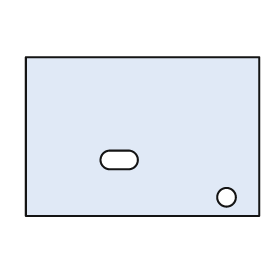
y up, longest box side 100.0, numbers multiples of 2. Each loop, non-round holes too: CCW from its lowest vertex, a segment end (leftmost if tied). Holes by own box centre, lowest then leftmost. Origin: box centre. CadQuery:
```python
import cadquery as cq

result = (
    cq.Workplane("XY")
    .moveTo(-50.0, -34.0)
    .lineTo(50.0, -34.0)
    .lineTo(50.0, 34.0)
    .lineTo(-50.0, 34.0)
    .close()
    .moveTo(36.0, -26.0)
    .circle(4.0)
    .moveTo(-14.0, -14.0)
    .lineTo(-6.0, -14.0)
    .threePointArc((-2.0, -10.0), (-6.0, -6.0))
    .lineTo(-14.0, -6.0)
    .threePointArc((-18.0, -10.0), (-14.0, -14.0))
    .close()
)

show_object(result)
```